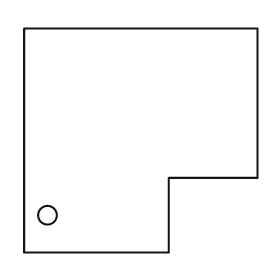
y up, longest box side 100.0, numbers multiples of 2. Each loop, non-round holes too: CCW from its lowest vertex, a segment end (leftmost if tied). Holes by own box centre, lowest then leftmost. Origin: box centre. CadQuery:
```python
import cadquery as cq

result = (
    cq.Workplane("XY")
    .moveTo(-50.0, -48.0)
    .lineTo(12.0, -48.0)
    .lineTo(12.0, -16.0)
    .lineTo(50.0, -16.0)
    .lineTo(50.0, 48.0)
    .lineTo(-50.0, 48.0)
    .close()
    .moveTo(-40.0, -32.0)
    .circle(4.0)
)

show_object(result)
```